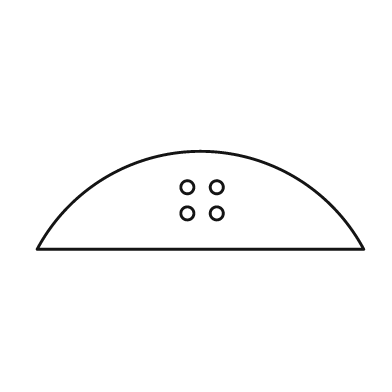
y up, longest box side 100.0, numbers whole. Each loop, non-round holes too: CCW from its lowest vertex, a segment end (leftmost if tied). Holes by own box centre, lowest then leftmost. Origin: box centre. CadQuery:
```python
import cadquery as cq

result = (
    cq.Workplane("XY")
    .moveTo(-50.0, -15.0)
    .lineTo(50.0, -15.0)
    .threePointArc((0.0, 15.0), (-50.0, -15.0))
    .close()
    .moveTo(-4.0, -4.0)
    .circle(2.0)
    .moveTo(5.0, -4.0)
    .circle(2.0)
    .moveTo(-4.0, 4.0)
    .circle(2.0)
    .moveTo(5.0, 4.0)
    .circle(2.0)
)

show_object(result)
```